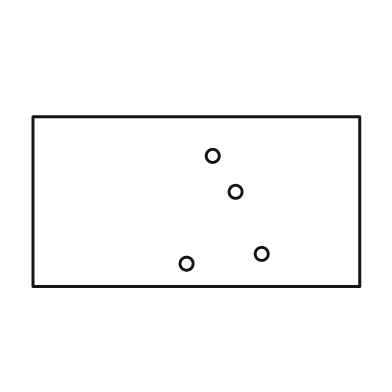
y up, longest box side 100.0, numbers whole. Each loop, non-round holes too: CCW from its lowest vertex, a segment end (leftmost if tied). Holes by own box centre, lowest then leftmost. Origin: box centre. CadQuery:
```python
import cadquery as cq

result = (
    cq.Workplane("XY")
    .moveTo(-50.0, -26.0)
    .lineTo(50.0, -26.0)
    .lineTo(50.0, 26.0)
    .lineTo(-50.0, 26.0)
    .close()
    .moveTo(-3.0, -19.0)
    .circle(2.0)
    .moveTo(20.0, -16.0)
    .circle(2.0)
    .moveTo(12.0, 3.0)
    .circle(2.0)
    .moveTo(5.0, 14.0)
    .circle(2.0)
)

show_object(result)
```